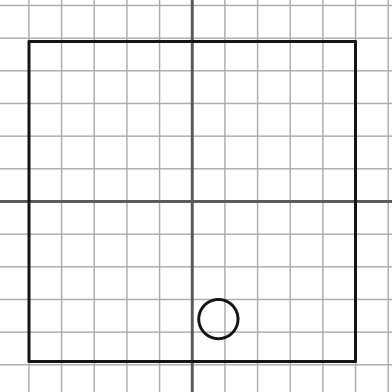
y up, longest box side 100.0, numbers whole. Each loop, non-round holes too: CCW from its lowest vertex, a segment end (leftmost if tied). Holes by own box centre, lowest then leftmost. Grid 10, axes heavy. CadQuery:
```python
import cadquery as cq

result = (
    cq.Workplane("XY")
    .moveTo(-50.0, -49.0)
    .lineTo(50.0, -49.0)
    .lineTo(50.0, 49.0)
    .lineTo(-50.0, 49.0)
    .close()
    .moveTo(8.0, -36.0)
    .circle(6.0)
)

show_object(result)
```